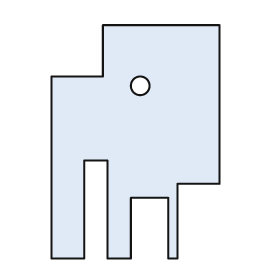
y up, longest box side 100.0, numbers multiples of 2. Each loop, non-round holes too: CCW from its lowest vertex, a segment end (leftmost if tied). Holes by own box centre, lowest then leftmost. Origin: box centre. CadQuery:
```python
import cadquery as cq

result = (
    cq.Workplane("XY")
    .moveTo(-36.0, -50.0)
    .lineTo(-22.0, -50.0)
    .lineTo(-22.0, -8.0)
    .lineTo(-12.0, -8.0)
    .lineTo(-12.0, -50.0)
    .lineTo(-2.0, -50.0)
    .lineTo(-2.0, -24.0)
    .lineTo(14.0, -24.0)
    .lineTo(14.0, -50.0)
    .lineTo(18.0, -50.0)
    .lineTo(18.0, -18.0)
    .lineTo(36.0, -18.0)
    .lineTo(36.0, 50.0)
    .lineTo(-14.0, 50.0)
    .lineTo(-14.0, 28.0)
    .lineTo(-36.0, 28.0)
    .close()
    .moveTo(2.0, 24.0)
    .circle(4.0)
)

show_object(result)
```